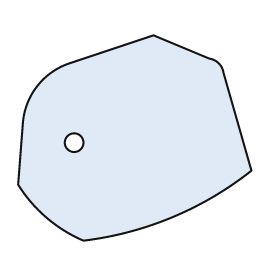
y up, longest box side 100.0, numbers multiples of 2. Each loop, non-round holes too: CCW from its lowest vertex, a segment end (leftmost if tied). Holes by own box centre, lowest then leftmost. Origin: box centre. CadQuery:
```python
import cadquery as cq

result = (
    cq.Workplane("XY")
    .moveTo(-22.0, -44.0)
    .threePointArc((16.0, -34.0), (50.0, -14.0))
    .lineTo(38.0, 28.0)
    .threePointArc((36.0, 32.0), (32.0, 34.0))
    .lineTo(8.0, 44.0)
    .lineTo(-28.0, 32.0)
    .threePointArc((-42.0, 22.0), (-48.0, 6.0))
    .lineTo(-50.0, -20.0)
    .threePointArc((-38.0, -34.0), (-22.0, -44.0))
    .close()
    .moveTo(-26.0, -2.0)
    .circle(4.0)
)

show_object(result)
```